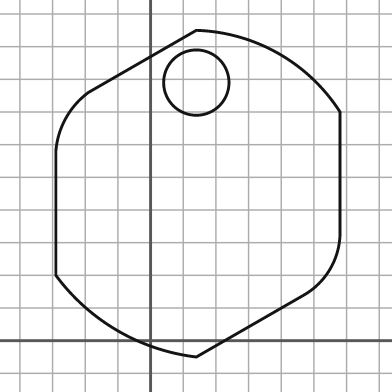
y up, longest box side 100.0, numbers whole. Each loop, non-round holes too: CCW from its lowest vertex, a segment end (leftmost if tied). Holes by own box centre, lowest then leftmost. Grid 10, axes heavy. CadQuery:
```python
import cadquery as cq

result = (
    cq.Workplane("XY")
    .moveTo(14.0, -5.0)
    .lineTo(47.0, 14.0)
    .threePointArc((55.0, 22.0), (58.0, 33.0))
    .lineTo(58.0, 70.0)
    .threePointArc((39.0, 88.0), (14.0, 95.0))
    .lineTo(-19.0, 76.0)
    .threePointArc((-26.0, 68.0), (-29.0, 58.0))
    .lineTo(-29.0, 20.0)
    .threePointArc((-10.0, 3.0), (14.0, -5.0))
    .close()
    .moveTo(14.0, 79.0)
    .circle(10.0)
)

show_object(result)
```